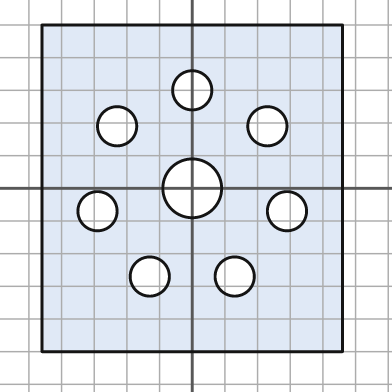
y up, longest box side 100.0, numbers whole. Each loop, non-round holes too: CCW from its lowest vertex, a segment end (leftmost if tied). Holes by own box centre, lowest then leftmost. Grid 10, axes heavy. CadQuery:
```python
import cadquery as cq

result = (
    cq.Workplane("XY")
    .moveTo(-46.0, -50.0)
    .lineTo(46.0, -50.0)
    .lineTo(46.0, 50.0)
    .lineTo(-46.0, 50.0)
    .close()
    .moveTo(-13.0, -27.0)
    .circle(6.0)
    .moveTo(13.0, -27.0)
    .circle(6.0)
    .moveTo(-29.0, -7.0)
    .circle(6.0)
    .moveTo(29.0, -7.0)
    .circle(6.0)
    .moveTo(0.0, 0.0)
    .circle(9.0)
    .moveTo(-23.0, 19.0)
    .circle(6.0)
    .moveTo(23.0, 19.0)
    .circle(6.0)
    .moveTo(0.0, 30.0)
    .circle(6.0)
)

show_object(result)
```